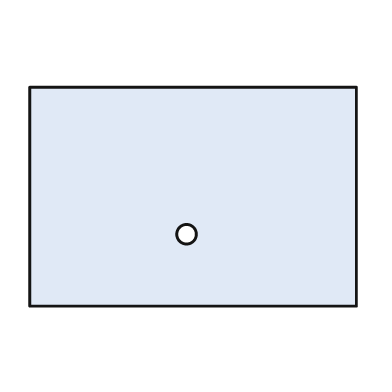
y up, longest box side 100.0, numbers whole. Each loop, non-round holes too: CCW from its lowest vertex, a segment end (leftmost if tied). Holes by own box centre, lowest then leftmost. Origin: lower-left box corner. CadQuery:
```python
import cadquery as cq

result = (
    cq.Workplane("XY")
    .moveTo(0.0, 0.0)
    .lineTo(100.0, 0.0)
    .lineTo(100.0, 67.0)
    .lineTo(0.0, 67.0)
    .close()
    .moveTo(48.0, 22.0)
    .circle(3.0)
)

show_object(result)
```